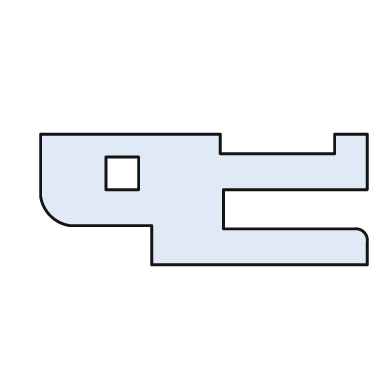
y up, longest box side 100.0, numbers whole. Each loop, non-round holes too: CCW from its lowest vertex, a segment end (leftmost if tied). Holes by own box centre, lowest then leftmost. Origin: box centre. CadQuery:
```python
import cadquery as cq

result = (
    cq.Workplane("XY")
    .moveTo(-16.0, -20.0)
    .lineTo(50.0, -20.0)
    .lineTo(50.0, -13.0)
    .threePointArc((49.0, -10.0), (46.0, -9.0))
    .lineTo(6.0, -9.0)
    .lineTo(6.0, 3.0)
    .lineTo(50.0, 3.0)
    .lineTo(50.0, 20.0)
    .lineTo(40.0, 20.0)
    .lineTo(40.0, 14.0)
    .lineTo(5.0, 14.0)
    .lineTo(5.0, 20.0)
    .lineTo(-50.0, 20.0)
    .lineTo(-50.0, 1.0)
    .threePointArc((-47.0, -5.0), (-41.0, -8.0))
    .lineTo(-16.0, -8.0)
    .close()
    .moveTo(-30.0, 3.0)
    .lineTo(-20.0, 3.0)
    .lineTo(-20.0, 13.0)
    .lineTo(-30.0, 13.0)
    .close()
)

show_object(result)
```